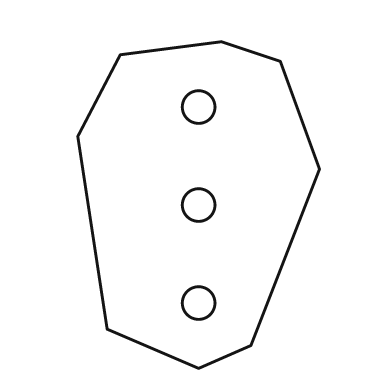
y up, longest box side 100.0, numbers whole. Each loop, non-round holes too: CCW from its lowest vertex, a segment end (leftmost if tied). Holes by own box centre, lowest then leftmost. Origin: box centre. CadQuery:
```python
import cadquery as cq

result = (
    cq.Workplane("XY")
    .moveTo(0.0, -50.0)
    .lineTo(16.0, -43.0)
    .lineTo(37.0, 11.0)
    .lineTo(25.0, 44.0)
    .lineTo(7.0, 50.0)
    .lineTo(-24.0, 46.0)
    .lineTo(-37.0, 21.0)
    .lineTo(-28.0, -38.0)
    .close()
    .moveTo(0.0, -30.0)
    .circle(5.0)
    .moveTo(0.0, 0.0)
    .circle(5.0)
    .moveTo(0.0, 30.0)
    .circle(5.0)
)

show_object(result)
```